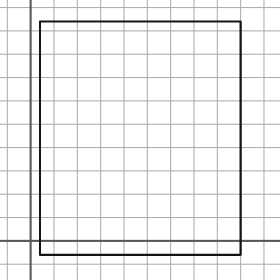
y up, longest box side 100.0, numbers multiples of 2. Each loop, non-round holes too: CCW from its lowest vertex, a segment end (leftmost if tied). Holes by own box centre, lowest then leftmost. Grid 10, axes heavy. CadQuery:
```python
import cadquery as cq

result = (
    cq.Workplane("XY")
    .moveTo(4.0, -6.0)
    .lineTo(90.0, -6.0)
    .lineTo(90.0, 94.0)
    .lineTo(4.0, 94.0)
    .close()
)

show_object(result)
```